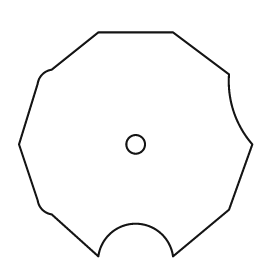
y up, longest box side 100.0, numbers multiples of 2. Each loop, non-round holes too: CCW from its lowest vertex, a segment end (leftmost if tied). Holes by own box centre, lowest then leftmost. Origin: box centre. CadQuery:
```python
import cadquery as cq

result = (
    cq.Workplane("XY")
    .moveTo(-16.0, -48.0)
    .threePointArc((0.0, -34.0), (16.0, -48.0))
    .lineTo(40.0, -28.0)
    .lineTo(50.0, 0.0)
    .threePointArc((42.0, 14.0), (40.0, 30.0))
    .lineTo(16.0, 48.0)
    .lineTo(-16.0, 48.0)
    .lineTo(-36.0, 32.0)
    .threePointArc((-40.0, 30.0), (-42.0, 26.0))
    .lineTo(-50.0, 0.0)
    .lineTo(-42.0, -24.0)
    .threePointArc((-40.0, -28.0), (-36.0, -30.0))
    .close()
    .moveTo(0.0, 0.0)
    .circle(4.0)
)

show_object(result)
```